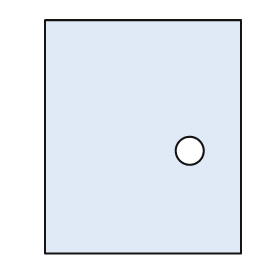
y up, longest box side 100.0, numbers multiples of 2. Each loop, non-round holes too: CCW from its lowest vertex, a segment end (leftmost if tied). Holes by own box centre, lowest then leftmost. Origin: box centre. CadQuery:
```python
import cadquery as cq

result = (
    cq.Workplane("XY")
    .moveTo(-42.0, -50.0)
    .lineTo(42.0, -50.0)
    .lineTo(42.0, 50.0)
    .lineTo(-42.0, 50.0)
    .close()
    .moveTo(20.0, -6.0)
    .circle(6.0)
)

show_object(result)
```